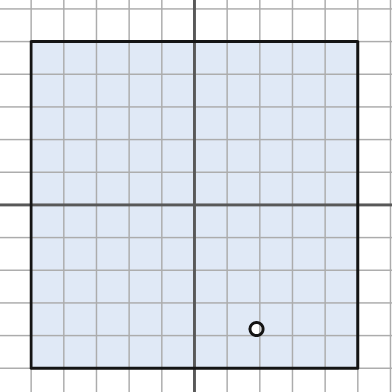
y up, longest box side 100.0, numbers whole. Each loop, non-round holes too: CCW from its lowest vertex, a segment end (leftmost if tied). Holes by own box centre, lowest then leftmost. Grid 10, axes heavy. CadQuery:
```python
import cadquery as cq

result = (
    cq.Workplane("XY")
    .moveTo(-50.0, -50.0)
    .lineTo(50.0, -50.0)
    .lineTo(50.0, 50.0)
    .lineTo(-50.0, 50.0)
    .close()
    .moveTo(19.0, -38.0)
    .circle(2.0)
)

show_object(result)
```